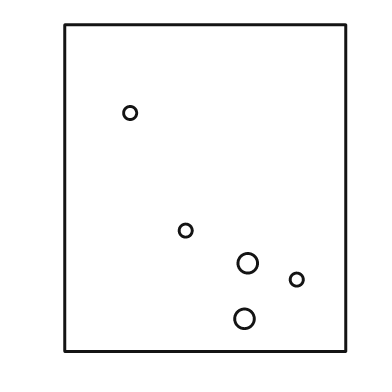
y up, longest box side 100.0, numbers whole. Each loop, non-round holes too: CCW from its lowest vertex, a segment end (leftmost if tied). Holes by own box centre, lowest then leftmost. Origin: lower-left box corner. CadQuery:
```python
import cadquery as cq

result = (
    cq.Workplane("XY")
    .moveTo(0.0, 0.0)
    .lineTo(86.0, 0.0)
    .lineTo(86.0, 100.0)
    .lineTo(0.0, 100.0)
    .close()
    .moveTo(55.0, 10.0)
    .circle(3.0)
    .moveTo(71.0, 22.0)
    .circle(2.0)
    .moveTo(56.0, 27.0)
    .circle(3.0)
    .moveTo(37.0, 37.0)
    .circle(2.0)
    .moveTo(20.0, 73.0)
    .circle(2.0)
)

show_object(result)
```